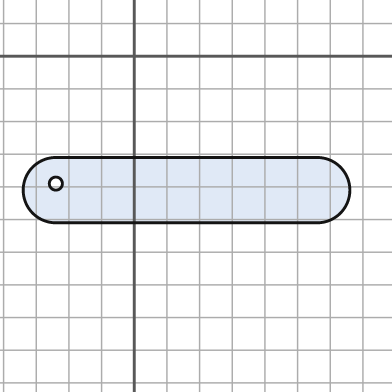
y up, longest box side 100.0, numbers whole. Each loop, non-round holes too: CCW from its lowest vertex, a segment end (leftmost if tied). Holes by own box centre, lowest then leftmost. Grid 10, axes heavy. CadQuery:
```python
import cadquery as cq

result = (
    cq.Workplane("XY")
    .moveTo(-24.0, -51.0)
    .lineTo(56.0, -51.0)
    .threePointArc((66.0, -41.0), (56.0, -31.0))
    .lineTo(-24.0, -31.0)
    .threePointArc((-34.0, -41.0), (-24.0, -51.0))
    .close()
    .moveTo(-24.0, -39.0)
    .circle(2.0)
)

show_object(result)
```